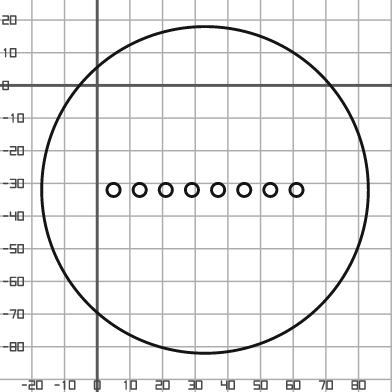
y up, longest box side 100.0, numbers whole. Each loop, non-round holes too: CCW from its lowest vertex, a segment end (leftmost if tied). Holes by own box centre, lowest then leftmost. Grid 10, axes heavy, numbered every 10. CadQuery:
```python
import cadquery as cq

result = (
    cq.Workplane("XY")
    .moveTo(33.0, -32.0)
    .circle(50.0)
    .moveTo(5.0, -32.0)
    .circle(2.0)
    .moveTo(13.0, -32.0)
    .circle(2.0)
    .moveTo(21.0, -32.0)
    .circle(2.0)
    .moveTo(29.0, -32.0)
    .circle(2.0)
    .moveTo(37.0, -32.0)
    .circle(2.0)
    .moveTo(45.0, -32.0)
    .circle(2.0)
    .moveTo(53.0, -32.0)
    .circle(2.0)
    .moveTo(61.0, -32.0)
    .circle(2.0)
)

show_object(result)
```